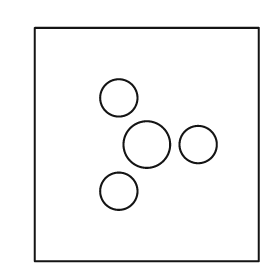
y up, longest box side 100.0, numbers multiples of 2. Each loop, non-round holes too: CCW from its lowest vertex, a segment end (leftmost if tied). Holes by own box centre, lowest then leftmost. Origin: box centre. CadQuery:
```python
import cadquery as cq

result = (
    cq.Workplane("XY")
    .moveTo(-48.0, -50.0)
    .lineTo(48.0, -50.0)
    .lineTo(48.0, 50.0)
    .lineTo(-48.0, 50.0)
    .close()
    .moveTo(-12.0, -20.0)
    .circle(8.0)
    .moveTo(0.0, 0.0)
    .circle(10.0)
    .moveTo(22.0, 0.0)
    .circle(8.0)
    .moveTo(-12.0, 20.0)
    .circle(8.0)
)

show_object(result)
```